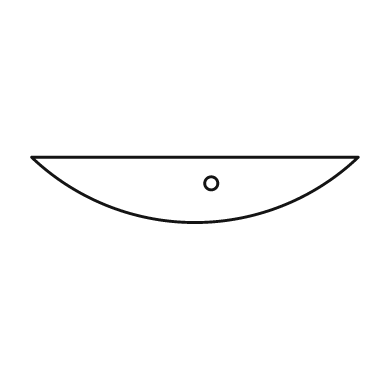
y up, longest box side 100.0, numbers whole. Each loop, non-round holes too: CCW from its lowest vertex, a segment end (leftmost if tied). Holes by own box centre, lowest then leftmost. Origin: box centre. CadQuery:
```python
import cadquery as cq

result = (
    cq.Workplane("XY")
    .moveTo(-50.0, 10.0)
    .threePointArc((0.0, -10.0), (50.0, 10.0))
    .close()
    .moveTo(5.0, 2.0)
    .circle(2.0)
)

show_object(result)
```